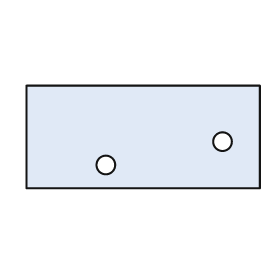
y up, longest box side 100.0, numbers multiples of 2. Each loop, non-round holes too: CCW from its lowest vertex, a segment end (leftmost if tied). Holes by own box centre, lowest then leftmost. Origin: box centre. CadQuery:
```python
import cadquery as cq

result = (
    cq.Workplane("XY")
    .moveTo(-50.0, -22.0)
    .lineTo(50.0, -22.0)
    .lineTo(50.0, 22.0)
    .lineTo(-50.0, 22.0)
    .close()
    .moveTo(-16.0, -12.0)
    .circle(4.0)
    .moveTo(34.0, -2.0)
    .circle(4.0)
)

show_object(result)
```